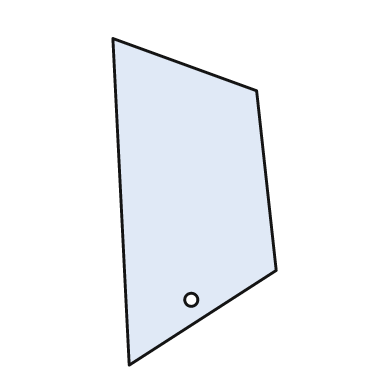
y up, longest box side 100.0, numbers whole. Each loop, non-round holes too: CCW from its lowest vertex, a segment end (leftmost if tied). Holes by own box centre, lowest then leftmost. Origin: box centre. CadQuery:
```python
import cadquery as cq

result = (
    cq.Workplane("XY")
    .moveTo(-20.0, -50.0)
    .lineTo(25.0, -21.0)
    .lineTo(19.0, 34.0)
    .lineTo(-25.0, 50.0)
    .close()
    .moveTo(-1.0, -30.0)
    .circle(2.0)
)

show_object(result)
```